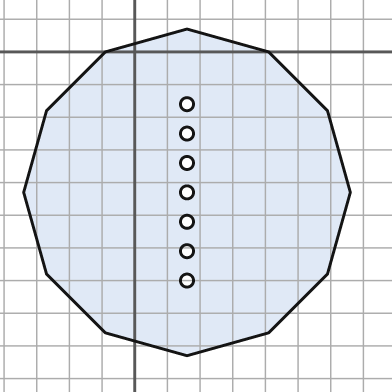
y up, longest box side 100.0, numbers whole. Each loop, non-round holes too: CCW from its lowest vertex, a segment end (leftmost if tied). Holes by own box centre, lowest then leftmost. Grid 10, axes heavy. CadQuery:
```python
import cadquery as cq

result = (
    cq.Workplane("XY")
    .moveTo(16.0, -93.0)
    .lineTo(41.0, -86.0)
    .lineTo(59.0, -68.0)
    .lineTo(66.0, -43.0)
    .lineTo(59.0, -18.0)
    .lineTo(41.0, 0.0)
    .lineTo(16.0, 7.0)
    .lineTo(-9.0, 0.0)
    .lineTo(-27.0, -18.0)
    .lineTo(-34.0, -43.0)
    .lineTo(-27.0, -68.0)
    .lineTo(-9.0, -86.0)
    .close()
    .moveTo(16.0, -70.0)
    .circle(2.0)
    .moveTo(16.0, -61.0)
    .circle(2.0)
    .moveTo(16.0, -52.0)
    .circle(2.0)
    .moveTo(16.0, -43.0)
    .circle(2.0)
    .moveTo(16.0, -34.0)
    .circle(2.0)
    .moveTo(16.0, -25.0)
    .circle(2.0)
    .moveTo(16.0, -16.0)
    .circle(2.0)
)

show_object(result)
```